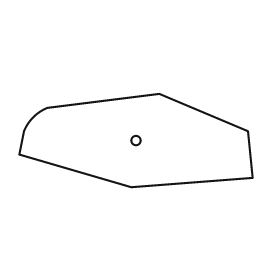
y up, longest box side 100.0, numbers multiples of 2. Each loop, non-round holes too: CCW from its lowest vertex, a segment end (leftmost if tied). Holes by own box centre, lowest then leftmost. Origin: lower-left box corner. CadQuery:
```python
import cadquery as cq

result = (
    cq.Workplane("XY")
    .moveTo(48.0, 0.0)
    .lineTo(100.0, 4.0)
    .lineTo(98.0, 24.0)
    .lineTo(60.0, 40.0)
    .lineTo(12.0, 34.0)
    .threePointArc((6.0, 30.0), (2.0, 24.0))
    .lineTo(0.0, 14.0)
    .close()
    .moveTo(50.0, 20.0)
    .circle(2.0)
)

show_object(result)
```